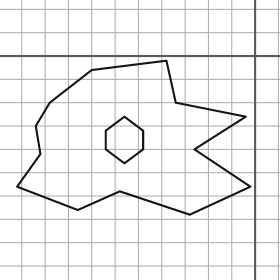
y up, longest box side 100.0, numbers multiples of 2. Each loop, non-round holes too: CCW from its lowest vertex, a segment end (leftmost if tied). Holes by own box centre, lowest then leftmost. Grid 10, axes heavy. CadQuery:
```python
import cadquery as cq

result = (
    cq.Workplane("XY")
    .moveTo(-28.0, -68.0)
    .lineTo(-2.0, -56.0)
    .lineTo(-26.0, -40.0)
    .lineTo(-4.0, -26.0)
    .lineTo(-34.0, -20.0)
    .lineTo(-38.0, -2.0)
    .lineTo(-70.0, -6.0)
    .lineTo(-88.0, -20.0)
    .lineTo(-94.0, -30.0)
    .lineTo(-92.0, -42.0)
    .lineTo(-102.0, -56.0)
    .lineTo(-76.0, -66.0)
    .lineTo(-58.0, -58.0)
    .close()
    .moveTo(-56.0, -46.0)
    .lineTo(-48.0, -40.0)
    .lineTo(-48.0, -32.0)
    .lineTo(-56.0, -26.0)
    .lineTo(-64.0, -32.0)
    .lineTo(-64.0, -40.0)
    .close()
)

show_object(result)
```